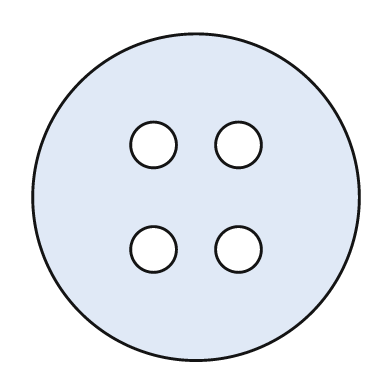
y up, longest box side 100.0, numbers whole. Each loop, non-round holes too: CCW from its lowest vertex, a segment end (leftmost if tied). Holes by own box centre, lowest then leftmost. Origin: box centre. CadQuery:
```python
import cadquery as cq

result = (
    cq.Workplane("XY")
    .moveTo(0.0, 0.0)
    .circle(50.0)
    .moveTo(-13.0, -16.0)
    .circle(7.0)
    .moveTo(13.0, -16.0)
    .circle(7.0)
    .moveTo(-13.0, 16.0)
    .circle(7.0)
    .moveTo(13.0, 16.0)
    .circle(7.0)
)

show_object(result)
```